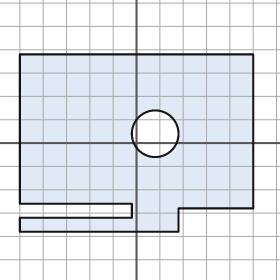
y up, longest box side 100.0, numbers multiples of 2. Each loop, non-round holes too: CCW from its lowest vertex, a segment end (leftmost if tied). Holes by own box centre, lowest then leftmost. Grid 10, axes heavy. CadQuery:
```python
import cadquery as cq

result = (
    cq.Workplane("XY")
    .moveTo(-50.0, -38.0)
    .lineTo(18.0, -38.0)
    .lineTo(18.0, -28.0)
    .lineTo(50.0, -28.0)
    .lineTo(50.0, 38.0)
    .lineTo(-50.0, 38.0)
    .lineTo(-50.0, -26.0)
    .lineTo(-2.0, -26.0)
    .lineTo(-2.0, -32.0)
    .lineTo(-50.0, -32.0)
    .close()
    .moveTo(8.0, 4.0)
    .circle(10.0)
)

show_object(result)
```